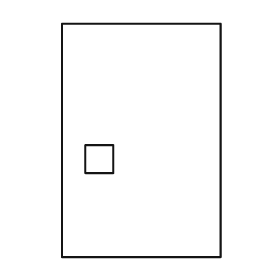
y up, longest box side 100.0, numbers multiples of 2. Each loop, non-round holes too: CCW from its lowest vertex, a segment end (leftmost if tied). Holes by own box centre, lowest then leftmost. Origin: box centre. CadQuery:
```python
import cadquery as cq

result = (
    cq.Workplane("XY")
    .moveTo(-34.0, -50.0)
    .lineTo(34.0, -50.0)
    .lineTo(34.0, 50.0)
    .lineTo(-34.0, 50.0)
    .close()
    .moveTo(-24.0, -14.0)
    .lineTo(-12.0, -14.0)
    .lineTo(-12.0, -2.0)
    .lineTo(-24.0, -2.0)
    .close()
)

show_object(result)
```